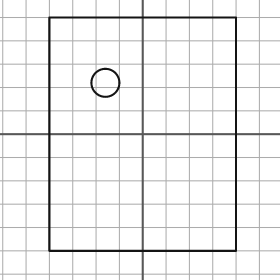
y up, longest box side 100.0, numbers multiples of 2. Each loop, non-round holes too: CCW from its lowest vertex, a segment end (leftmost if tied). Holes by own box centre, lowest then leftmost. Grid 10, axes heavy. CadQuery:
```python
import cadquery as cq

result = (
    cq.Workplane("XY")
    .moveTo(-40.0, -50.0)
    .lineTo(40.0, -50.0)
    .lineTo(40.0, 50.0)
    .lineTo(-40.0, 50.0)
    .close()
    .moveTo(-16.0, 22.0)
    .circle(6.0)
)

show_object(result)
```